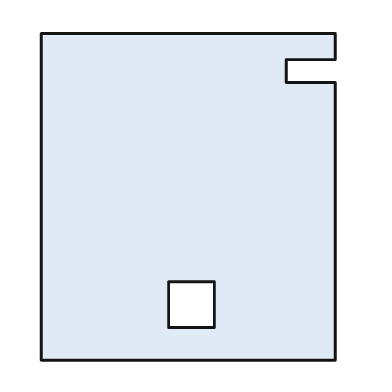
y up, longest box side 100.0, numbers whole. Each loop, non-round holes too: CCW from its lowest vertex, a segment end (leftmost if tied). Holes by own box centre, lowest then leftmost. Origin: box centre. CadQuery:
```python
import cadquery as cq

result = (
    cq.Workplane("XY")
    .moveTo(-45.0, -50.0)
    .lineTo(45.0, -50.0)
    .lineTo(45.0, 35.0)
    .lineTo(30.0, 35.0)
    .lineTo(30.0, 42.0)
    .lineTo(45.0, 42.0)
    .lineTo(45.0, 50.0)
    .lineTo(-45.0, 50.0)
    .close()
    .moveTo(-6.0, -40.0)
    .lineTo(8.0, -40.0)
    .lineTo(8.0, -26.0)
    .lineTo(-6.0, -26.0)
    .close()
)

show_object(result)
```